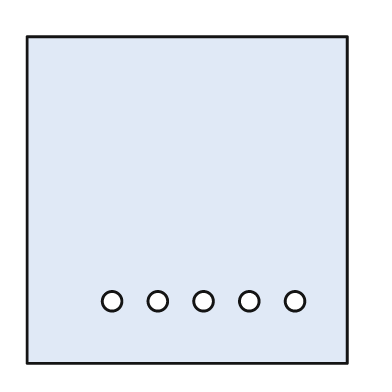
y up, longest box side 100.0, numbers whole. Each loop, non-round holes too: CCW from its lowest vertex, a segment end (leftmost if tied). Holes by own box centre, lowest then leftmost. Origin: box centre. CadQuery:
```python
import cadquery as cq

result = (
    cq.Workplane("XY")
    .moveTo(-49.0, -50.0)
    .lineTo(49.0, -50.0)
    .lineTo(49.0, 50.0)
    .lineTo(-49.0, 50.0)
    .close()
    .moveTo(-23.0, -31.0)
    .circle(3.0)
    .moveTo(-9.0, -31.0)
    .circle(3.0)
    .moveTo(5.0, -31.0)
    .circle(3.0)
    .moveTo(19.0, -31.0)
    .circle(3.0)
    .moveTo(33.0, -31.0)
    .circle(3.0)
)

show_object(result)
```